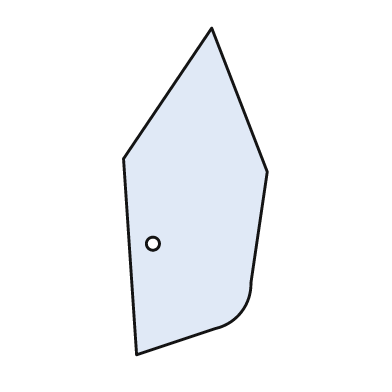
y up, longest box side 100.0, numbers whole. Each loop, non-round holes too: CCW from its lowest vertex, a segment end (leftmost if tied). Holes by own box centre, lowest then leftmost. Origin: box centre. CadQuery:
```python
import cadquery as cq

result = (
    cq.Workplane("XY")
    .moveTo(-18.0, -50.0)
    .lineTo(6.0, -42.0)
    .threePointArc((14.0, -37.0), (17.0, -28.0))
    .lineTo(22.0, 6.0)
    .lineTo(5.0, 50.0)
    .lineTo(-22.0, 10.0)
    .close()
    .moveTo(-13.0, -16.0)
    .circle(2.0)
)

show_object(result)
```